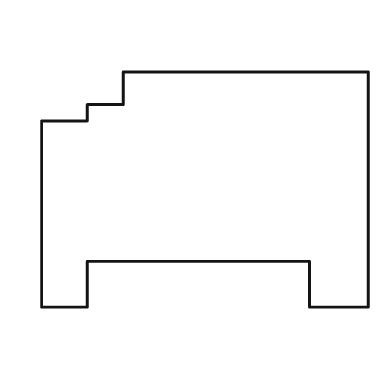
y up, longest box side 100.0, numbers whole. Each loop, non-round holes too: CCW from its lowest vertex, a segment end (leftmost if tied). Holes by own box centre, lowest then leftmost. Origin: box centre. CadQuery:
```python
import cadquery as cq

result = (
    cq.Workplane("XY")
    .moveTo(-50.0, -36.0)
    .lineTo(-36.0, -36.0)
    .lineTo(-36.0, -22.0)
    .lineTo(32.0, -22.0)
    .lineTo(32.0, -36.0)
    .lineTo(50.0, -36.0)
    .lineTo(50.0, 36.0)
    .lineTo(-25.0, 36.0)
    .lineTo(-25.0, 26.0)
    .lineTo(-36.0, 26.0)
    .lineTo(-36.0, 21.0)
    .lineTo(-50.0, 21.0)
    .close()
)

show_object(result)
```